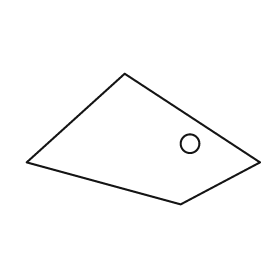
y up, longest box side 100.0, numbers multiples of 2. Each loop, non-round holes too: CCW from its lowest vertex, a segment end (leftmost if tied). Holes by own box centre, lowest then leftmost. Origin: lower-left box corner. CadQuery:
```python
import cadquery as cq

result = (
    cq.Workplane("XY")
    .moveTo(66.0, 0.0)
    .lineTo(100.0, 18.0)
    .lineTo(42.0, 56.0)
    .lineTo(0.0, 18.0)
    .close()
    .moveTo(70.0, 26.0)
    .circle(4.0)
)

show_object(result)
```